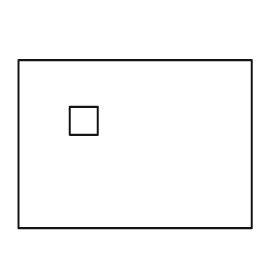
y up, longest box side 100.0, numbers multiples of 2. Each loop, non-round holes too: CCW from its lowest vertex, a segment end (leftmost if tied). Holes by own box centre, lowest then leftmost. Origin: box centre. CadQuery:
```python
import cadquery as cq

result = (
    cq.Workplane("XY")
    .moveTo(-50.0, -36.0)
    .lineTo(50.0, -36.0)
    .lineTo(50.0, 36.0)
    .lineTo(-50.0, 36.0)
    .close()
    .moveTo(-28.0, 4.0)
    .lineTo(-16.0, 4.0)
    .lineTo(-16.0, 16.0)
    .lineTo(-28.0, 16.0)
    .close()
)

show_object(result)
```